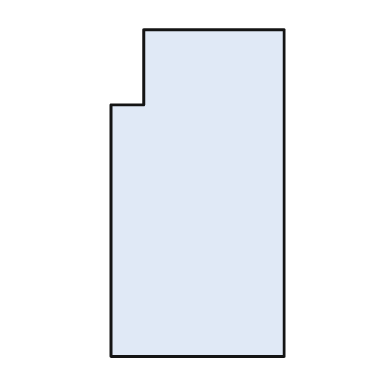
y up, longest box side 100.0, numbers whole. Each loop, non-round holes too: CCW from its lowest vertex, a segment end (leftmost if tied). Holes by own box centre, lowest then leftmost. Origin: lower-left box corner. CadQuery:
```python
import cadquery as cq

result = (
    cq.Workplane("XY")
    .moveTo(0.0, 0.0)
    .lineTo(53.0, 0.0)
    .lineTo(53.0, 100.0)
    .lineTo(10.0, 100.0)
    .lineTo(10.0, 77.0)
    .lineTo(0.0, 77.0)
    .close()
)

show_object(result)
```